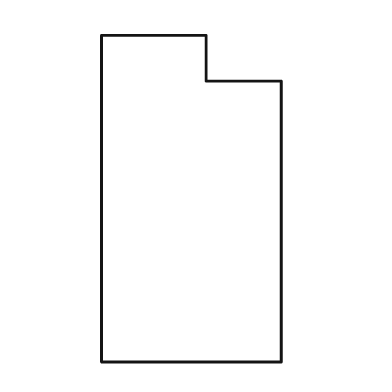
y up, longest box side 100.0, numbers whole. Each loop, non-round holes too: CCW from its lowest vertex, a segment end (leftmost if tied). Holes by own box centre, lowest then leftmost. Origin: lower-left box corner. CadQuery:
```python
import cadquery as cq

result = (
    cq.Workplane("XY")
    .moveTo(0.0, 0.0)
    .lineTo(55.0, 0.0)
    .lineTo(55.0, 86.0)
    .lineTo(32.0, 86.0)
    .lineTo(32.0, 100.0)
    .lineTo(0.0, 100.0)
    .close()
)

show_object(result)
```